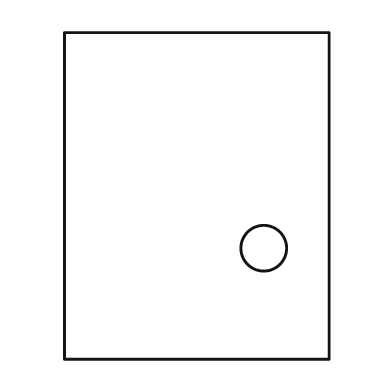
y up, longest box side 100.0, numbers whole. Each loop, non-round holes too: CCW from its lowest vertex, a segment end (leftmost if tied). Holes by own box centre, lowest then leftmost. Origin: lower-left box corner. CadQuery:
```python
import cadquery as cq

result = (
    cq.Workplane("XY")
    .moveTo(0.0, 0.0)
    .lineTo(81.0, 0.0)
    .lineTo(81.0, 100.0)
    .lineTo(0.0, 100.0)
    .close()
    .moveTo(61.0, 34.0)
    .circle(7.0)
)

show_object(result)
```